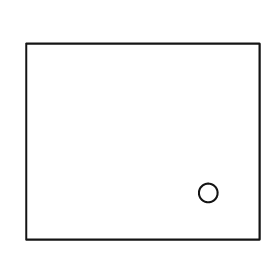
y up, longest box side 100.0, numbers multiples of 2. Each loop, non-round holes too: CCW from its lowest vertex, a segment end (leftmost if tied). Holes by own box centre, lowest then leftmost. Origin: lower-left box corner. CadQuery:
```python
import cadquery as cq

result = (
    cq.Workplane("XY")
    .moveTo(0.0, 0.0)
    .lineTo(100.0, 0.0)
    .lineTo(100.0, 84.0)
    .lineTo(0.0, 84.0)
    .close()
    .moveTo(78.0, 20.0)
    .circle(4.0)
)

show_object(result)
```